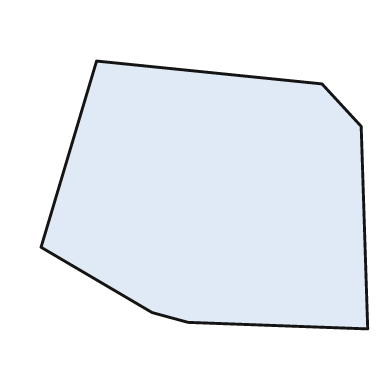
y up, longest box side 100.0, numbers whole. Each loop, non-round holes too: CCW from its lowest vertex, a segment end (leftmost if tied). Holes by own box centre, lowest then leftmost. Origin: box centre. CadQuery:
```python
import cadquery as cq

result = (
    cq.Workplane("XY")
    .moveTo(50.0, -41.0)
    .lineTo(48.0, 21.0)
    .lineTo(36.0, 34.0)
    .lineTo(-33.0, 41.0)
    .lineTo(-50.0, -16.0)
    .lineTo(-16.0, -36.0)
    .lineTo(-5.0, -39.0)
    .close()
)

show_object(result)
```